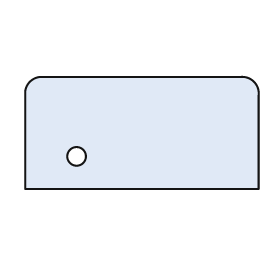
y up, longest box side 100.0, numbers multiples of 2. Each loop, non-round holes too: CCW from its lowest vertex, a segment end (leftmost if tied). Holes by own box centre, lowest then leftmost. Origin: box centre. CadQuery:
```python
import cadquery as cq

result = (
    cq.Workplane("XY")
    .moveTo(-50.0, -24.0)
    .lineTo(50.0, -24.0)
    .lineTo(50.0, 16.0)
    .threePointArc((48.0, 22.0), (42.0, 24.0))
    .lineTo(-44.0, 24.0)
    .threePointArc((-48.0, 22.0), (-50.0, 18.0))
    .close()
    .moveTo(-28.0, -10.0)
    .circle(4.0)
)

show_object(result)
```